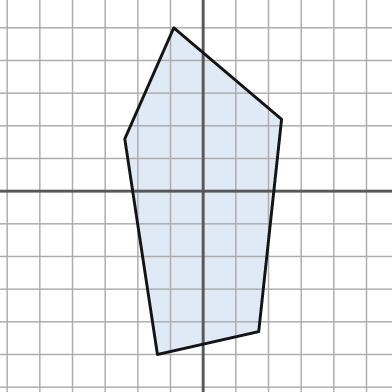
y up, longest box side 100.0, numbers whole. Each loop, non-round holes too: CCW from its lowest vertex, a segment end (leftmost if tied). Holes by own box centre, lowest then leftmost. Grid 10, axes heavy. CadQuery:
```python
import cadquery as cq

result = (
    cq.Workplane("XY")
    .moveTo(-14.0, -50.0)
    .lineTo(17.0, -43.0)
    .lineTo(24.0, 22.0)
    .lineTo(-9.0, 50.0)
    .lineTo(-24.0, 16.0)
    .close()
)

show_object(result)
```